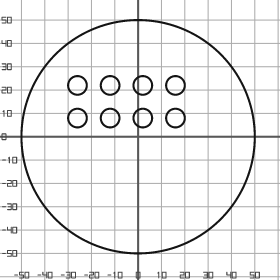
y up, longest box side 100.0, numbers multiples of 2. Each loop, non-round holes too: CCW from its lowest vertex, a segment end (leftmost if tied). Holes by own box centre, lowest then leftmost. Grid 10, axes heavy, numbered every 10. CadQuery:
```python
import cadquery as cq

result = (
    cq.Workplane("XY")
    .moveTo(0.0, 0.0)
    .circle(50.0)
    .moveTo(-26.0, 8.0)
    .circle(4.0)
    .moveTo(-12.0, 8.0)
    .circle(4.0)
    .moveTo(2.0, 8.0)
    .circle(4.0)
    .moveTo(16.0, 8.0)
    .circle(4.0)
    .moveTo(-26.0, 22.0)
    .circle(4.0)
    .moveTo(-12.0, 22.0)
    .circle(4.0)
    .moveTo(2.0, 22.0)
    .circle(4.0)
    .moveTo(16.0, 22.0)
    .circle(4.0)
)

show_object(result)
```